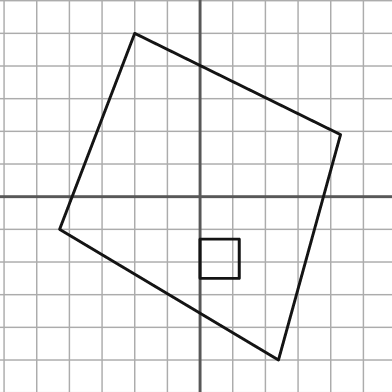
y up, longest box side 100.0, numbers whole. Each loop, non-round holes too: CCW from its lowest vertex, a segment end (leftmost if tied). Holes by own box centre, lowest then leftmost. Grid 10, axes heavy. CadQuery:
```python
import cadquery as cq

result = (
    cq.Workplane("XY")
    .moveTo(24.0, -50.0)
    .lineTo(43.0, 19.0)
    .lineTo(-20.0, 50.0)
    .lineTo(-43.0, -10.0)
    .close()
    .moveTo(0.0, -25.0)
    .lineTo(12.0, -25.0)
    .lineTo(12.0, -13.0)
    .lineTo(0.0, -13.0)
    .close()
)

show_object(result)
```